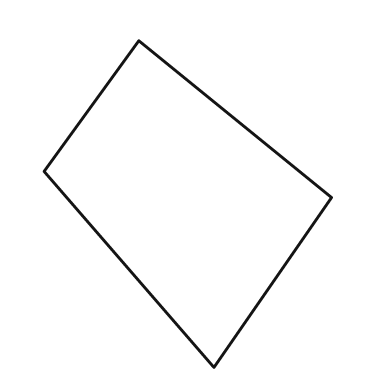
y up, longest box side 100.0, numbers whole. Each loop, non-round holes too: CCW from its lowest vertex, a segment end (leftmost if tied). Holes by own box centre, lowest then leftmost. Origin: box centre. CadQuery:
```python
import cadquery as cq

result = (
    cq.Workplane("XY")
    .moveTo(8.0, -50.0)
    .lineTo(44.0, 2.0)
    .lineTo(-15.0, 50.0)
    .lineTo(-44.0, 10.0)
    .close()
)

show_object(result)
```